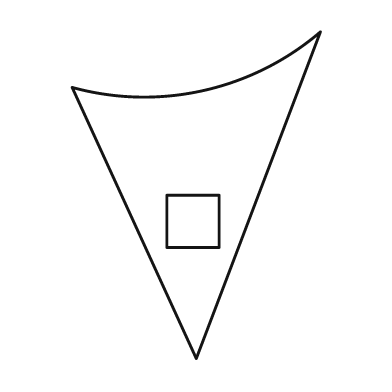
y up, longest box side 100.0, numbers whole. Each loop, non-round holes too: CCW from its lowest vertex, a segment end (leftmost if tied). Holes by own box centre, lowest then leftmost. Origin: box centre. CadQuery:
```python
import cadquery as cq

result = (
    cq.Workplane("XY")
    .moveTo(0.0, -50.0)
    .lineTo(38.0, 50.0)
    .threePointArc((2.0, 32.0), (-38.0, 33.0))
    .close()
    .moveTo(-9.0, -16.0)
    .lineTo(7.0, -16.0)
    .lineTo(7.0, 0.0)
    .lineTo(-9.0, 0.0)
    .close()
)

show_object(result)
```